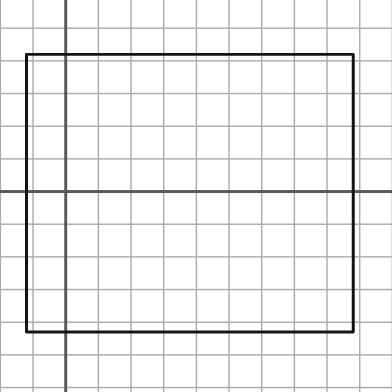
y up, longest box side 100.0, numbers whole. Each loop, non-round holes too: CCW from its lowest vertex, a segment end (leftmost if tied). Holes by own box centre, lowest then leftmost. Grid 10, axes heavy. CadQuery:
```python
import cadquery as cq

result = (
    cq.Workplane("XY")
    .moveTo(-12.0, -43.0)
    .lineTo(88.0, -43.0)
    .lineTo(88.0, 42.0)
    .lineTo(-12.0, 42.0)
    .close()
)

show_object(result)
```